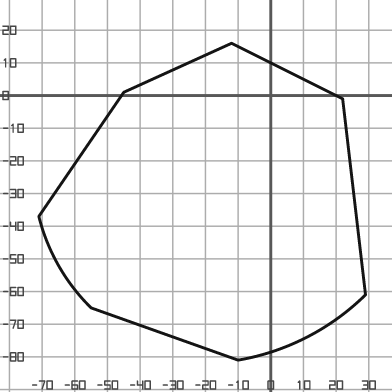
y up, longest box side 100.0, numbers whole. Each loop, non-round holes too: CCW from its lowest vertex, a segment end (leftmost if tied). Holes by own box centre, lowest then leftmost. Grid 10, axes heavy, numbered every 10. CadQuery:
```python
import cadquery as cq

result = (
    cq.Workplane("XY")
    .moveTo(-10.0, -81.0)
    .threePointArc((11.0, -74.0), (29.0, -61.0))
    .lineTo(22.0, -1.0)
    .lineTo(-12.0, 16.0)
    .lineTo(-45.0, 1.0)
    .lineTo(-71.0, -37.0)
    .threePointArc((-65.0, -52.0), (-55.0, -65.0))
    .close()
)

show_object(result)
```